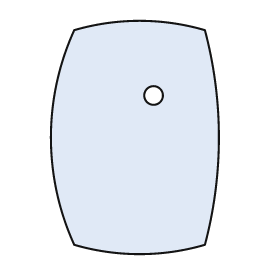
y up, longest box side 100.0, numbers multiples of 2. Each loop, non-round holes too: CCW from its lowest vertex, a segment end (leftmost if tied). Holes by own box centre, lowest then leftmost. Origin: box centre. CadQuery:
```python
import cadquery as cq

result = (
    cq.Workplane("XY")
    .moveTo(-26.0, -46.0)
    .threePointArc((2.0, -50.0), (30.0, -46.0))
    .threePointArc((36.0, 0.0), (30.0, 46.0))
    .threePointArc((2.0, 50.0), (-26.0, 46.0))
    .threePointArc((-36.0, 0.0), (-26.0, -46.0))
    .close()
    .moveTo(8.0, 18.0)
    .circle(4.0)
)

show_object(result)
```